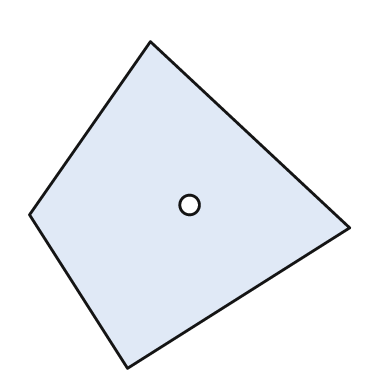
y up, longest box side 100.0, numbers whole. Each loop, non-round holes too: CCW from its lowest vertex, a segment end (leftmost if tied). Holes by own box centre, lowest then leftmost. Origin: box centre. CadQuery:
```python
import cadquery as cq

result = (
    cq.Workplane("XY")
    .moveTo(-19.0, -50.0)
    .lineTo(49.0, -7.0)
    .lineTo(-12.0, 50.0)
    .lineTo(-49.0, -3.0)
    .close()
    .moveTo(0.0, 0.0)
    .circle(3.0)
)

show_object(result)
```